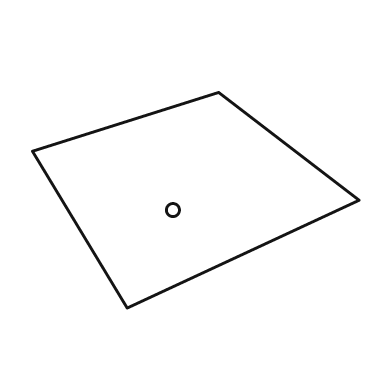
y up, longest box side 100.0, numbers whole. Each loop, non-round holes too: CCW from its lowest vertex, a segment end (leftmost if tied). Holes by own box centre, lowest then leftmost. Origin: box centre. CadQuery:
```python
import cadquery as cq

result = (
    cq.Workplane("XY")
    .moveTo(-21.0, -33.0)
    .lineTo(50.0, 0.0)
    .lineTo(7.0, 33.0)
    .lineTo(-50.0, 15.0)
    .close()
    .moveTo(-7.0, -3.0)
    .circle(2.0)
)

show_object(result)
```